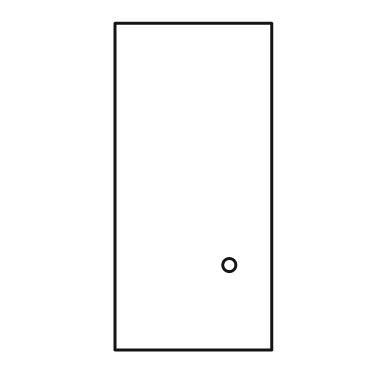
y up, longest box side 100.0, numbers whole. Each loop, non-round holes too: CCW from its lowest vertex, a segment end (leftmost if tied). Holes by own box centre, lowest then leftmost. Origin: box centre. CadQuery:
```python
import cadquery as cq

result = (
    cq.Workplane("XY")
    .moveTo(-24.0, -50.0)
    .lineTo(24.0, -50.0)
    .lineTo(24.0, 50.0)
    .lineTo(-24.0, 50.0)
    .close()
    .moveTo(11.0, -24.0)
    .circle(2.0)
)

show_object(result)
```